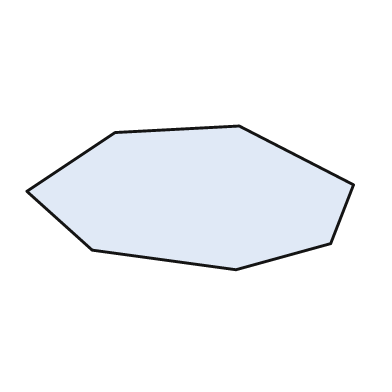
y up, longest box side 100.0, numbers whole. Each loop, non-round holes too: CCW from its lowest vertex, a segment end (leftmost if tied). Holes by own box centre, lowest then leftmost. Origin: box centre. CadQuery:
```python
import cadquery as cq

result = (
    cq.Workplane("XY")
    .moveTo(14.0, -22.0)
    .lineTo(43.0, -14.0)
    .lineTo(50.0, 4.0)
    .lineTo(15.0, 22.0)
    .lineTo(-23.0, 20.0)
    .lineTo(-50.0, 2.0)
    .lineTo(-30.0, -16.0)
    .close()
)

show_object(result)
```